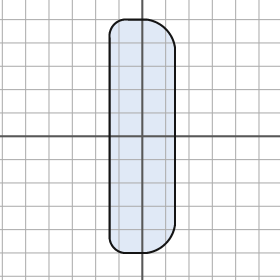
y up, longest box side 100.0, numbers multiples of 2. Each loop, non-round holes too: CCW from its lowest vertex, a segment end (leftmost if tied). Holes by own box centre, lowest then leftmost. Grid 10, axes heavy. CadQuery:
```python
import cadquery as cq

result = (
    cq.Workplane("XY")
    .moveTo(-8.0, -50.0)
    .lineTo(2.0, -50.0)
    .threePointArc((10.0, -46.0), (14.0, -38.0))
    .lineTo(14.0, 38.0)
    .threePointArc((10.0, 46.0), (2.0, 50.0))
    .lineTo(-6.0, 50.0)
    .threePointArc((-12.0, 48.0), (-14.0, 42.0))
    .lineTo(-14.0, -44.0)
    .threePointArc((-12.0, -48.0), (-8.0, -50.0))
    .close()
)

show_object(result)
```